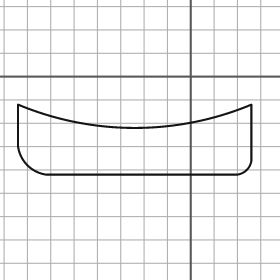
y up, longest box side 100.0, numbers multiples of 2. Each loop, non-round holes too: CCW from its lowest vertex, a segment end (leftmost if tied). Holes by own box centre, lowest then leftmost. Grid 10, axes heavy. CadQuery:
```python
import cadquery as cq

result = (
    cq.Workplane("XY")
    .moveTo(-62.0, -42.0)
    .lineTo(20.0, -42.0)
    .threePointArc((24.0, -40.0), (26.0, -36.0))
    .lineTo(26.0, -12.0)
    .threePointArc((-24.0, -22.0), (-74.0, -12.0))
    .lineTo(-74.0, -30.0)
    .threePointArc((-70.0, -38.0), (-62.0, -42.0))
    .close()
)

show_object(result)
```